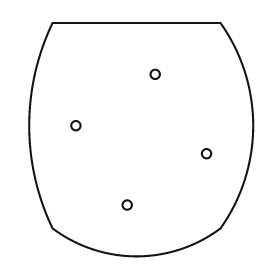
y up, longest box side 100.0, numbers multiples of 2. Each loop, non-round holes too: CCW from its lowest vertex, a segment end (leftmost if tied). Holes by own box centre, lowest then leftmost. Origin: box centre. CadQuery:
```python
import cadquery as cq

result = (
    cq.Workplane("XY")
    .moveTo(-38.0, -38.0)
    .threePointArc((-2.0, -50.0), (34.0, -38.0))
    .threePointArc((48.0, 6.0), (34.0, 50.0))
    .lineTo(-38.0, 50.0)
    .threePointArc((-48.0, 6.0), (-38.0, -38.0))
    .close()
    .moveTo(-6.0, -28.0)
    .circle(2.0)
    .moveTo(28.0, -6.0)
    .circle(2.0)
    .moveTo(-28.0, 6.0)
    .circle(2.0)
    .moveTo(6.0, 28.0)
    .circle(2.0)
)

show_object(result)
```